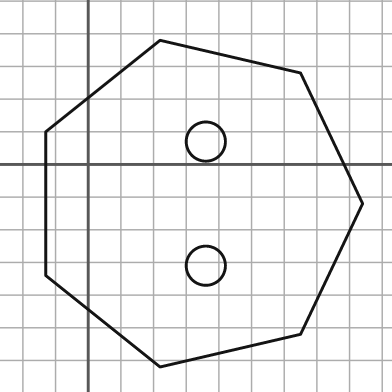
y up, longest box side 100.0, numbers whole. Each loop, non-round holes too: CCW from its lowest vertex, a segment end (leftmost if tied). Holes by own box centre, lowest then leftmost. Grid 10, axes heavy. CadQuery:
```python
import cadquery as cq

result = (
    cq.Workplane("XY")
    .moveTo(22.0, -62.0)
    .lineTo(65.0, -52.0)
    .lineTo(84.0, -12.0)
    .lineTo(65.0, 28.0)
    .lineTo(22.0, 38.0)
    .lineTo(-13.0, 10.0)
    .lineTo(-13.0, -34.0)
    .close()
    .moveTo(36.0, -31.0)
    .circle(6.0)
    .moveTo(36.0, 7.0)
    .circle(6.0)
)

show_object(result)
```